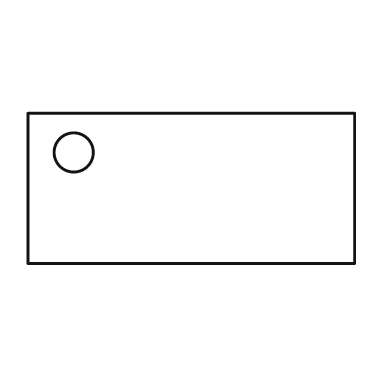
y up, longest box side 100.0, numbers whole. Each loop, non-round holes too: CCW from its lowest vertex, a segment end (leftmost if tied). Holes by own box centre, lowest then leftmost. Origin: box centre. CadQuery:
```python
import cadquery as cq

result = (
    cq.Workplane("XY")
    .moveTo(-50.0, -23.0)
    .lineTo(50.0, -23.0)
    .lineTo(50.0, 23.0)
    .lineTo(-50.0, 23.0)
    .close()
    .moveTo(-36.0, 11.0)
    .circle(6.0)
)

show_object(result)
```